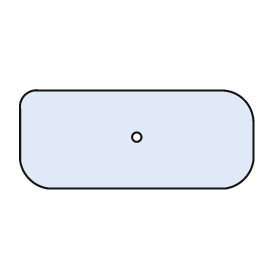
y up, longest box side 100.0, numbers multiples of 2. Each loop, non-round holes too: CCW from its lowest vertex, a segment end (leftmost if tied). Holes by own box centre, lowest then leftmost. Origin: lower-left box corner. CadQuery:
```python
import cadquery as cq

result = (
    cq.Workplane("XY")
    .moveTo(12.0, 0.0)
    .lineTo(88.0, 0.0)
    .threePointArc((96.0, 4.0), (100.0, 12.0))
    .lineTo(100.0, 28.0)
    .threePointArc((96.0, 38.0), (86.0, 42.0))
    .lineTo(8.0, 42.0)
    .threePointArc((2.0, 40.0), (0.0, 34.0))
    .lineTo(0.0, 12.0)
    .threePointArc((4.0, 4.0), (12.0, 0.0))
    .close()
    .moveTo(50.0, 22.0)
    .circle(2.0)
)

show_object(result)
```